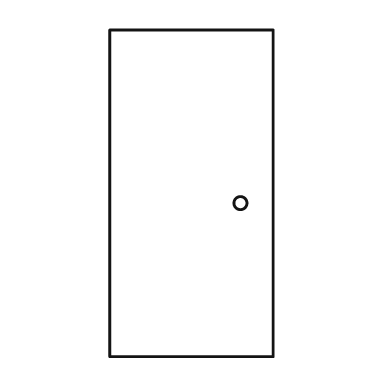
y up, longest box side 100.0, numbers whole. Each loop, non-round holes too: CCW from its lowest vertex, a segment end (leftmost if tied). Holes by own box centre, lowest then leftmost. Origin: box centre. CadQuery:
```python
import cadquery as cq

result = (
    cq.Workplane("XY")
    .moveTo(-25.0, -50.0)
    .lineTo(25.0, -50.0)
    .lineTo(25.0, 50.0)
    .lineTo(-25.0, 50.0)
    .close()
    .moveTo(15.0, -3.0)
    .circle(2.0)
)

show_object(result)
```